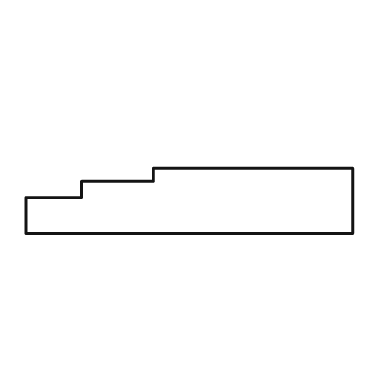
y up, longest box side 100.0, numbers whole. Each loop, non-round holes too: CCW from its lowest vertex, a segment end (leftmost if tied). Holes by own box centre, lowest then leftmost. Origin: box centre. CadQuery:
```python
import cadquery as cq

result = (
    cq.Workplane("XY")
    .moveTo(-50.0, -10.0)
    .lineTo(50.0, -10.0)
    .lineTo(50.0, 10.0)
    .lineTo(-11.0, 10.0)
    .lineTo(-11.0, 6.0)
    .lineTo(-33.0, 6.0)
    .lineTo(-33.0, 1.0)
    .lineTo(-50.0, 1.0)
    .close()
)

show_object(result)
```